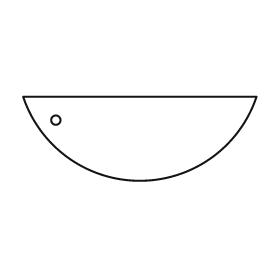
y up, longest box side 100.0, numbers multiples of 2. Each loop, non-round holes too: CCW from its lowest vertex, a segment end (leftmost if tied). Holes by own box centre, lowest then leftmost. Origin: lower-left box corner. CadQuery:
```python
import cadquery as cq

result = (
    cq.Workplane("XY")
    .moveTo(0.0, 36.0)
    .threePointArc((50.0, 0.0), (100.0, 36.0))
    .close()
    .moveTo(14.0, 26.0)
    .circle(2.0)
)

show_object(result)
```